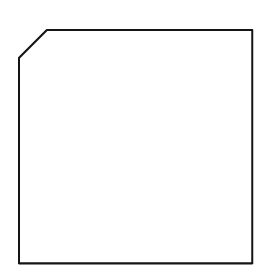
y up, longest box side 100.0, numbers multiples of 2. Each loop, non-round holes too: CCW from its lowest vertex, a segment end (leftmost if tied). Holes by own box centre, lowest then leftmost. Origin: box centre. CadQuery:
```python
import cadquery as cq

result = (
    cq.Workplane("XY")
    .moveTo(-50.0, -50.0)
    .lineTo(50.0, -50.0)
    .lineTo(50.0, 50.0)
    .lineTo(-38.0, 50.0)
    .lineTo(-50.0, 38.0)
    .close()
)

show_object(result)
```